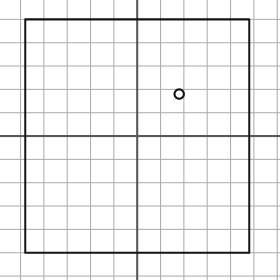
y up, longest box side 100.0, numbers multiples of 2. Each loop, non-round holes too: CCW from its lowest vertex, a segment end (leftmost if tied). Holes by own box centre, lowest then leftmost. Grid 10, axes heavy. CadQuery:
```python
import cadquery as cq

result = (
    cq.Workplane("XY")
    .moveTo(-48.0, -50.0)
    .lineTo(48.0, -50.0)
    .lineTo(48.0, 50.0)
    .lineTo(-48.0, 50.0)
    .close()
    .moveTo(18.0, 18.0)
    .circle(2.0)
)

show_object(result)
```